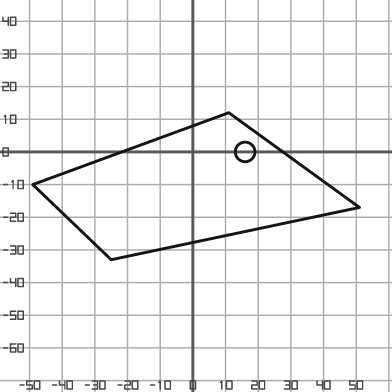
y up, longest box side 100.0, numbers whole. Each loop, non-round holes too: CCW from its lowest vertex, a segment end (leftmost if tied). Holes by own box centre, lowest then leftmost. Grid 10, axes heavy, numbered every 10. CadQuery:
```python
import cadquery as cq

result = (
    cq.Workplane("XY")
    .moveTo(-25.0, -33.0)
    .lineTo(51.0, -17.0)
    .lineTo(11.0, 12.0)
    .lineTo(-49.0, -10.0)
    .close()
    .moveTo(16.0, 0.0)
    .circle(3.0)
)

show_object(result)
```